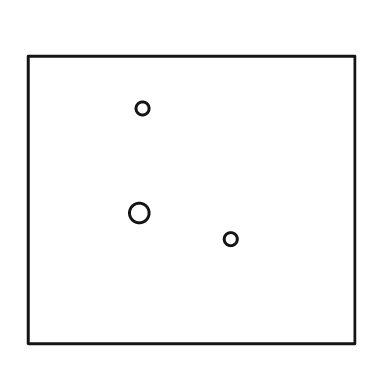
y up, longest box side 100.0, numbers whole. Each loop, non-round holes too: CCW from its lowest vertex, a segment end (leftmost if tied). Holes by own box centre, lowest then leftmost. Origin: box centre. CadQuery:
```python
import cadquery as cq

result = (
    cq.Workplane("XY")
    .moveTo(-50.0, -44.0)
    .lineTo(50.0, -44.0)
    .lineTo(50.0, 44.0)
    .lineTo(-50.0, 44.0)
    .close()
    .moveTo(12.0, -12.0)
    .circle(2.0)
    .moveTo(-16.0, -4.0)
    .circle(3.0)
    .moveTo(-15.0, 28.0)
    .circle(2.0)
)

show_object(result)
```